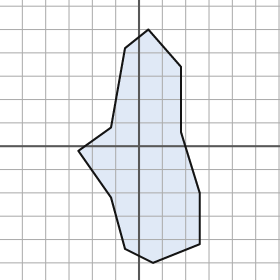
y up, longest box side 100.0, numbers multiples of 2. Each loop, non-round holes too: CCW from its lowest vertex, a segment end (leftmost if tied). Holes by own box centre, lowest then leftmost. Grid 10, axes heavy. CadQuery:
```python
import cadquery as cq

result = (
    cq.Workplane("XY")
    .moveTo(6.0, -50.0)
    .lineTo(26.0, -42.0)
    .lineTo(26.0, -20.0)
    .lineTo(18.0, 6.0)
    .lineTo(18.0, 34.0)
    .lineTo(4.0, 50.0)
    .lineTo(-6.0, 42.0)
    .lineTo(-12.0, 8.0)
    .lineTo(-26.0, -2.0)
    .lineTo(-12.0, -22.0)
    .lineTo(-6.0, -44.0)
    .close()
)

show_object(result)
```